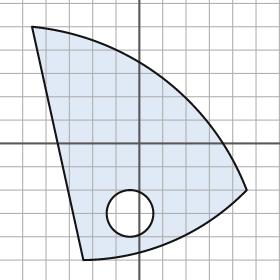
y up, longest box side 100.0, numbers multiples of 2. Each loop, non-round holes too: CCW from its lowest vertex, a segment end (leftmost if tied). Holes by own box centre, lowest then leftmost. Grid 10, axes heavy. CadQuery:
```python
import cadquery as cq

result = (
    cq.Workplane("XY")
    .moveTo(-24.0, -50.0)
    .threePointArc((14.0, -42.0), (46.0, -20.0))
    .threePointArc((10.0, 28.0), (-46.0, 50.0))
    .close()
    .moveTo(-4.0, -30.0)
    .circle(10.0)
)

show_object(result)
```